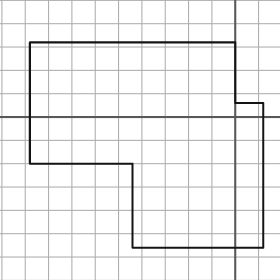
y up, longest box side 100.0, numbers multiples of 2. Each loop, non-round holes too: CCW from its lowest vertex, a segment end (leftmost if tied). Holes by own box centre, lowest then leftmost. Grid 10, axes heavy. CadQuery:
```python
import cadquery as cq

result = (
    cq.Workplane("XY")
    .moveTo(-44.0, -56.0)
    .lineTo(12.0, -56.0)
    .lineTo(12.0, 6.0)
    .lineTo(0.0, 6.0)
    .lineTo(0.0, 32.0)
    .lineTo(-88.0, 32.0)
    .lineTo(-88.0, -20.0)
    .lineTo(-44.0, -20.0)
    .close()
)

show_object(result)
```